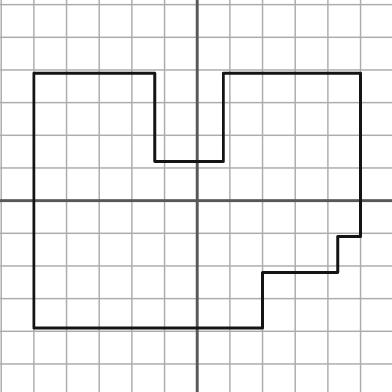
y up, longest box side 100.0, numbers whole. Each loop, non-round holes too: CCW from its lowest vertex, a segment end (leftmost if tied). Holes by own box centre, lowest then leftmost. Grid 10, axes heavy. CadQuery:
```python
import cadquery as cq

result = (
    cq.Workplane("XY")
    .moveTo(-50.0, -39.0)
    .lineTo(20.0, -39.0)
    .lineTo(20.0, -22.0)
    .lineTo(43.0, -22.0)
    .lineTo(43.0, -11.0)
    .lineTo(50.0, -11.0)
    .lineTo(50.0, 39.0)
    .lineTo(8.0, 39.0)
    .lineTo(8.0, 12.0)
    .lineTo(-13.0, 12.0)
    .lineTo(-13.0, 39.0)
    .lineTo(-50.0, 39.0)
    .close()
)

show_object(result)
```